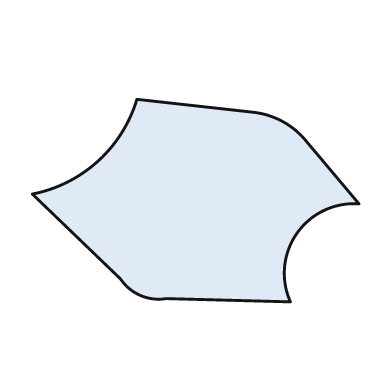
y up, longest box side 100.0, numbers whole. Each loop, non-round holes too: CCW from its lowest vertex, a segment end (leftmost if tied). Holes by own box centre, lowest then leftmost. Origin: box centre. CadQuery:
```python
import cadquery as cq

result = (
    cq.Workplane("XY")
    .moveTo(29.0, -31.0)
    .threePointArc((31.0, -10.0), (50.0, -1.0))
    .lineTo(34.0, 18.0)
    .threePointArc((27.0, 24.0), (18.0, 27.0))
    .lineTo(-18.0, 31.0)
    .threePointArc((-30.0, 12.0), (-50.0, 2.0))
    .lineTo(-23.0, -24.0)
    .threePointArc((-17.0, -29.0), (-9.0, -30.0))
    .close()
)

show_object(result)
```